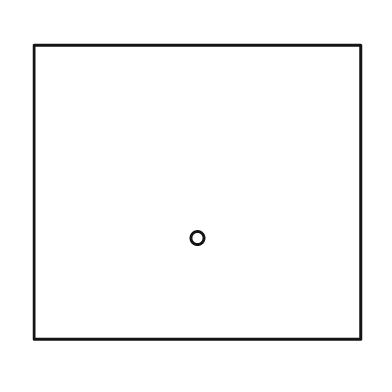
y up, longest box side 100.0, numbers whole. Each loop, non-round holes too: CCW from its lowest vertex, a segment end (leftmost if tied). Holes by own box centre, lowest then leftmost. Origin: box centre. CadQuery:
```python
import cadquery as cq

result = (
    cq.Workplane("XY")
    .moveTo(-50.0, -45.0)
    .lineTo(50.0, -45.0)
    .lineTo(50.0, 45.0)
    .lineTo(-50.0, 45.0)
    .close()
    .moveTo(0.0, -14.0)
    .circle(2.0)
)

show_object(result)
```